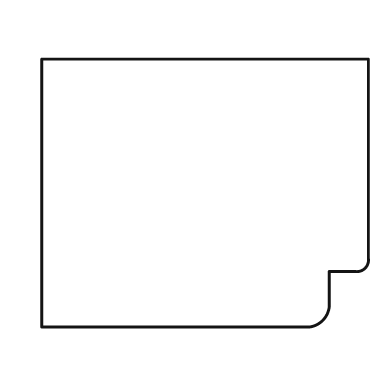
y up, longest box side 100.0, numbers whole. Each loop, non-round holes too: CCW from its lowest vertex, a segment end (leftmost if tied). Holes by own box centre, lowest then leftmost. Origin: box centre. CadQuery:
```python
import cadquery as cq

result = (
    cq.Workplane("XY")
    .moveTo(-50.0, -41.0)
    .lineTo(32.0, -41.0)
    .threePointArc((36.0, -39.0), (38.0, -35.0))
    .lineTo(38.0, -24.0)
    .lineTo(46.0, -24.0)
    .threePointArc((49.0, -23.0), (50.0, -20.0))
    .lineTo(50.0, 41.0)
    .lineTo(-50.0, 41.0)
    .close()
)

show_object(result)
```